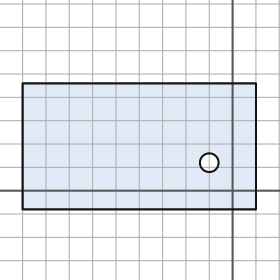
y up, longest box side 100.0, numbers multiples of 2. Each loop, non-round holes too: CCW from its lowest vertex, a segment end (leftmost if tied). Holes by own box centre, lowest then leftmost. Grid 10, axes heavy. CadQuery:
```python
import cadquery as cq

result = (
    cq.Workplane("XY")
    .moveTo(-90.0, -8.0)
    .lineTo(10.0, -8.0)
    .lineTo(10.0, 46.0)
    .lineTo(-90.0, 46.0)
    .close()
    .moveTo(-10.0, 12.0)
    .circle(4.0)
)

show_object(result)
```